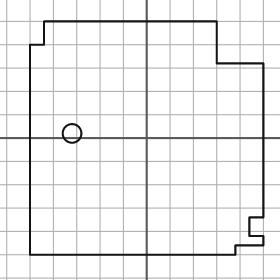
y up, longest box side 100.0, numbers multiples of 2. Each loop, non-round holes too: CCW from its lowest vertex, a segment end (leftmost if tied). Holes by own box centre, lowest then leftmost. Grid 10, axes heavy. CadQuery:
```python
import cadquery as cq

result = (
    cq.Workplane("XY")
    .moveTo(-50.0, -50.0)
    .lineTo(38.0, -50.0)
    .lineTo(38.0, -46.0)
    .lineTo(50.0, -46.0)
    .lineTo(50.0, -42.0)
    .lineTo(44.0, -42.0)
    .lineTo(44.0, -34.0)
    .lineTo(50.0, -34.0)
    .lineTo(50.0, 32.0)
    .lineTo(30.0, 32.0)
    .lineTo(30.0, 50.0)
    .lineTo(-44.0, 50.0)
    .lineTo(-44.0, 40.0)
    .lineTo(-50.0, 40.0)
    .close()
    .moveTo(-32.0, 2.0)
    .circle(4.0)
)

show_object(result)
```